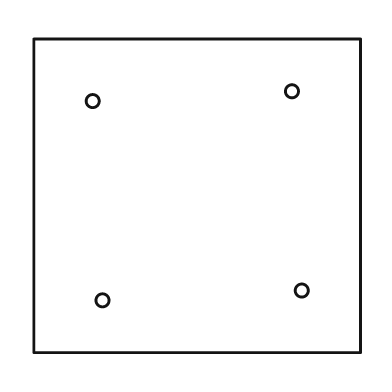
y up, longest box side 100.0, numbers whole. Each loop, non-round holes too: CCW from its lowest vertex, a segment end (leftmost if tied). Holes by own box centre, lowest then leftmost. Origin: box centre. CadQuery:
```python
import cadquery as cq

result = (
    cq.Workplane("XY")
    .moveTo(-50.0, -48.0)
    .lineTo(50.0, -48.0)
    .lineTo(50.0, 48.0)
    .lineTo(-50.0, 48.0)
    .close()
    .moveTo(-29.0, -32.0)
    .circle(2.0)
    .moveTo(32.0, -29.0)
    .circle(2.0)
    .moveTo(-32.0, 29.0)
    .circle(2.0)
    .moveTo(29.0, 32.0)
    .circle(2.0)
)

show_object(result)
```